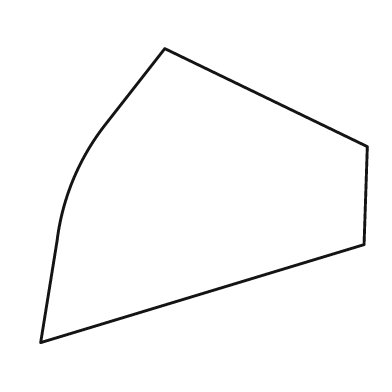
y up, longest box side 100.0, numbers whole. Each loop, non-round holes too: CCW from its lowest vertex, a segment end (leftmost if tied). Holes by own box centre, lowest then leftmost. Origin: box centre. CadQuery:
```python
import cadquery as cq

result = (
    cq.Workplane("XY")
    .moveTo(-50.0, -45.0)
    .lineTo(49.0, -15.0)
    .lineTo(50.0, 15.0)
    .lineTo(-12.0, 45.0)
    .lineTo(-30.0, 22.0)
    .threePointArc((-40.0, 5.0), (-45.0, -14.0))
    .close()
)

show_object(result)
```